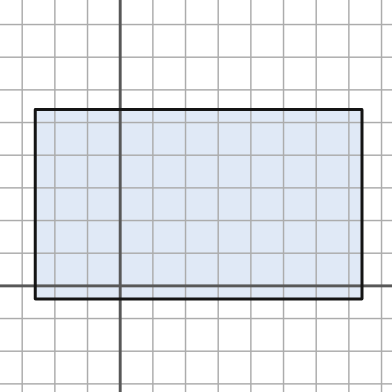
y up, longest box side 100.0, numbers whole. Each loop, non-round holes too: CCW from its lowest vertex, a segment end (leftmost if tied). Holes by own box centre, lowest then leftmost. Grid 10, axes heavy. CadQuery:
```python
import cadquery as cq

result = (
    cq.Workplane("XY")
    .moveTo(-26.0, -4.0)
    .lineTo(74.0, -4.0)
    .lineTo(74.0, 54.0)
    .lineTo(-26.0, 54.0)
    .close()
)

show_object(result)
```